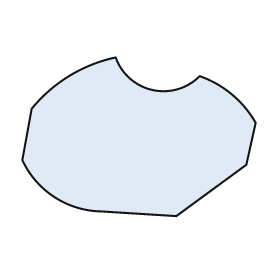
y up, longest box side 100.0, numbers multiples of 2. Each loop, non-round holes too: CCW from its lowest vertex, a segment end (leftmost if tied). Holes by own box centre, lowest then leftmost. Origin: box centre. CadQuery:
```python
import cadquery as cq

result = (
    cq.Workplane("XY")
    .moveTo(16.0, -34.0)
    .lineTo(46.0, -12.0)
    .lineTo(50.0, 6.0)
    .threePointArc((40.0, 18.0), (26.0, 26.0))
    .threePointArc((6.0, 20.0), (-10.0, 34.0))
    .threePointArc((-30.0, 26.0), (-46.0, 12.0))
    .lineTo(-50.0, -10.0)
    .threePointArc((-36.0, -26.0), (-16.0, -32.0))
    .close()
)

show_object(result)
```